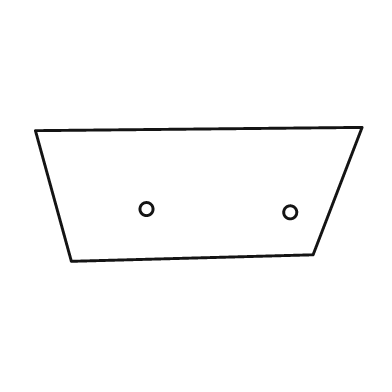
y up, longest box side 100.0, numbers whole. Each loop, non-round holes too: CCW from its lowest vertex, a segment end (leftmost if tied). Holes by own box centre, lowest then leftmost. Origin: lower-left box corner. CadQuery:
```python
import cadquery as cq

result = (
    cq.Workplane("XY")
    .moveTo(11.0, 0.0)
    .lineTo(85.0, 2.0)
    .lineTo(100.0, 41.0)
    .lineTo(0.0, 40.0)
    .close()
    .moveTo(78.0, 15.0)
    .circle(2.0)
    .moveTo(34.0, 16.0)
    .circle(2.0)
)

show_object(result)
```